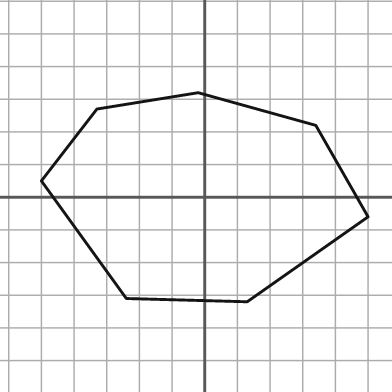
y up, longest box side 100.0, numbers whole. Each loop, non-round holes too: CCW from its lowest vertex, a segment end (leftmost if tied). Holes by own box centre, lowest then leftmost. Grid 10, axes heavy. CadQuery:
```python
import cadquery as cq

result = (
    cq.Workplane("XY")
    .moveTo(13.0, -32.0)
    .lineTo(50.0, -6.0)
    .lineTo(34.0, 22.0)
    .lineTo(-2.0, 32.0)
    .lineTo(-33.0, 27.0)
    .lineTo(-50.0, 5.0)
    .lineTo(-24.0, -31.0)
    .close()
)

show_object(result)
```